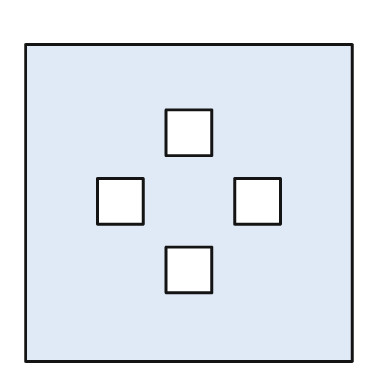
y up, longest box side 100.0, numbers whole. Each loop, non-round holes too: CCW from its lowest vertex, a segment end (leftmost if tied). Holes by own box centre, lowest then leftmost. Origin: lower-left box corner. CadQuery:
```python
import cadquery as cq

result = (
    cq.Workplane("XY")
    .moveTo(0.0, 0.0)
    .lineTo(100.0, 0.0)
    .lineTo(100.0, 97.0)
    .lineTo(0.0, 97.0)
    .close()
    .moveTo(43.0, 21.0)
    .lineTo(57.0, 21.0)
    .lineTo(57.0, 35.0)
    .lineTo(43.0, 35.0)
    .close()
    .moveTo(22.0, 42.0)
    .lineTo(36.0, 42.0)
    .lineTo(36.0, 56.0)
    .lineTo(22.0, 56.0)
    .close()
    .moveTo(64.0, 42.0)
    .lineTo(78.0, 42.0)
    .lineTo(78.0, 56.0)
    .lineTo(64.0, 56.0)
    .close()
    .moveTo(43.0, 63.0)
    .lineTo(57.0, 63.0)
    .lineTo(57.0, 77.0)
    .lineTo(43.0, 77.0)
    .close()
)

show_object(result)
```